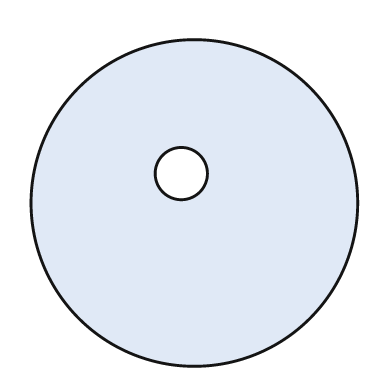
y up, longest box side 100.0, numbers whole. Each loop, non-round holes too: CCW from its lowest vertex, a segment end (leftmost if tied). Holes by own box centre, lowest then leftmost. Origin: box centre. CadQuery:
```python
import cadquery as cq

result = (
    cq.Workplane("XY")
    .moveTo(0.0, 0.0)
    .circle(50.0)
    .moveTo(-4.0, 9.0)
    .circle(8.0)
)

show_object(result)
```